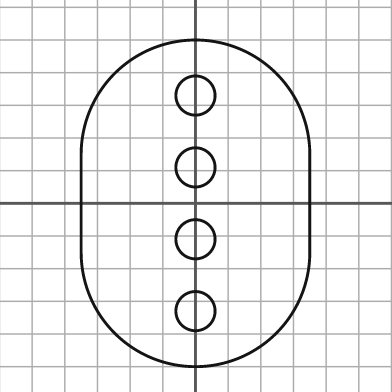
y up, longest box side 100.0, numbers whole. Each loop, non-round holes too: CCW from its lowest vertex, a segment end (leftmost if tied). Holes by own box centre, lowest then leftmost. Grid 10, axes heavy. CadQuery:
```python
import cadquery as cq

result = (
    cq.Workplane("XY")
    .moveTo(-35.0, -15.0)
    .threePointArc((0.0, -50.0), (35.0, -15.0))
    .lineTo(35.0, 15.0)
    .threePointArc((0.0, 50.0), (-35.0, 15.0))
    .close()
    .moveTo(0.0, -33.0)
    .circle(6.0)
    .moveTo(0.0, -11.0)
    .circle(6.0)
    .moveTo(0.0, 11.0)
    .circle(6.0)
    .moveTo(0.0, 33.0)
    .circle(6.0)
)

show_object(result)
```